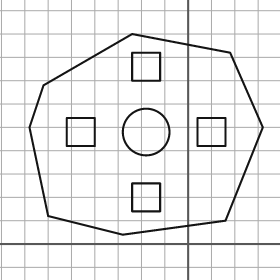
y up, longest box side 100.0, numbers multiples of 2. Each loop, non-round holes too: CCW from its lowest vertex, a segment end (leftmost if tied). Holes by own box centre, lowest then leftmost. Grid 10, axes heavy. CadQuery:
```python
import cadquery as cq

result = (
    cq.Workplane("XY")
    .moveTo(-28.0, 4.0)
    .lineTo(16.0, 10.0)
    .lineTo(32.0, 50.0)
    .lineTo(18.0, 82.0)
    .lineTo(-24.0, 90.0)
    .lineTo(-62.0, 68.0)
    .lineTo(-68.0, 50.0)
    .lineTo(-60.0, 12.0)
    .close()
    .moveTo(-24.0, 14.0)
    .lineTo(-12.0, 14.0)
    .lineTo(-12.0, 26.0)
    .lineTo(-24.0, 26.0)
    .close()
    .moveTo(-52.0, 42.0)
    .lineTo(-40.0, 42.0)
    .lineTo(-40.0, 54.0)
    .lineTo(-52.0, 54.0)
    .close()
    .moveTo(-18.0, 48.0)
    .circle(10.0)
    .moveTo(4.0, 42.0)
    .lineTo(16.0, 42.0)
    .lineTo(16.0, 54.0)
    .lineTo(4.0, 54.0)
    .close()
    .moveTo(-24.0, 70.0)
    .lineTo(-12.0, 70.0)
    .lineTo(-12.0, 82.0)
    .lineTo(-24.0, 82.0)
    .close()
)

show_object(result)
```